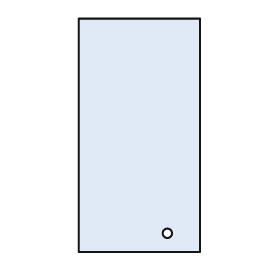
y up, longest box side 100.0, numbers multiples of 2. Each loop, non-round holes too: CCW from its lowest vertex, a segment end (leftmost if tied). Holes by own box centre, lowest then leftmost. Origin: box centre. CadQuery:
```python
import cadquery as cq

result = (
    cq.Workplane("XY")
    .moveTo(-26.0, -50.0)
    .lineTo(26.0, -50.0)
    .lineTo(26.0, 50.0)
    .lineTo(-26.0, 50.0)
    .close()
    .moveTo(12.0, -42.0)
    .circle(2.0)
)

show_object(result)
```